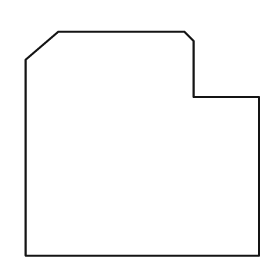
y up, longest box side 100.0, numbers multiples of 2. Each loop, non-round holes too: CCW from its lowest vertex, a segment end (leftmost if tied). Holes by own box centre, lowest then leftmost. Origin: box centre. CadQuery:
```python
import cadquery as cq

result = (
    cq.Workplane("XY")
    .moveTo(-50.0, -48.0)
    .lineTo(50.0, -48.0)
    .lineTo(50.0, 20.0)
    .lineTo(22.0, 20.0)
    .lineTo(22.0, 44.0)
    .lineTo(18.0, 48.0)
    .lineTo(-36.0, 48.0)
    .lineTo(-50.0, 36.0)
    .close()
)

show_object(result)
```